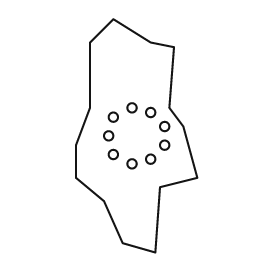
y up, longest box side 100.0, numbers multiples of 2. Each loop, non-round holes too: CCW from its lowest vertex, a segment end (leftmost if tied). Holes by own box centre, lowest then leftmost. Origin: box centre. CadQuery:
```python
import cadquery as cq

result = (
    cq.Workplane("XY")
    .moveTo(8.0, -50.0)
    .lineTo(10.0, -22.0)
    .lineTo(26.0, -18.0)
    .lineTo(20.0, 4.0)
    .lineTo(14.0, 12.0)
    .lineTo(16.0, 38.0)
    .lineTo(6.0, 40.0)
    .lineTo(-10.0, 50.0)
    .lineTo(-20.0, 40.0)
    .lineTo(-20.0, 12.0)
    .lineTo(-26.0, -4.0)
    .lineTo(-26.0, -18.0)
    .lineTo(-14.0, -28.0)
    .lineTo(-6.0, -46.0)
    .close()
    .moveTo(-2.0, -12.0)
    .circle(2.0)
    .moveTo(6.0, -10.0)
    .circle(2.0)
    .moveTo(-10.0, -8.0)
    .circle(2.0)
    .moveTo(12.0, -4.0)
    .circle(2.0)
    .moveTo(-12.0, 0.0)
    .circle(2.0)
    .moveTo(12.0, 4.0)
    .circle(2.0)
    .moveTo(-10.0, 8.0)
    .circle(2.0)
    .moveTo(6.0, 10.0)
    .circle(2.0)
    .moveTo(-2.0, 12.0)
    .circle(2.0)
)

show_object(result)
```